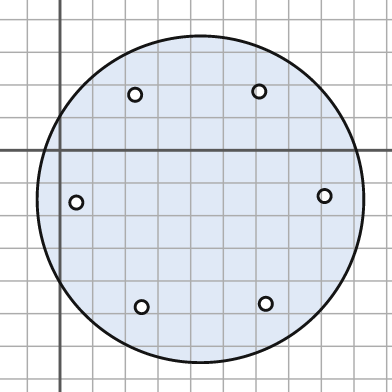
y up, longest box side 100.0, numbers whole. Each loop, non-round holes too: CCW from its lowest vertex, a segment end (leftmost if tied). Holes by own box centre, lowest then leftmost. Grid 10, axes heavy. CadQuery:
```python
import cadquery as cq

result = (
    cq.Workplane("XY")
    .moveTo(43.0, -15.0)
    .circle(50.0)
    .moveTo(25.0, -48.0)
    .circle(2.0)
    .moveTo(63.0, -47.0)
    .circle(2.0)
    .moveTo(5.0, -16.0)
    .circle(2.0)
    .moveTo(81.0, -14.0)
    .circle(2.0)
    .moveTo(23.0, 17.0)
    .circle(2.0)
    .moveTo(61.0, 18.0)
    .circle(2.0)
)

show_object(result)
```